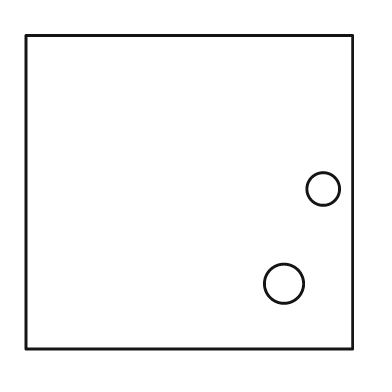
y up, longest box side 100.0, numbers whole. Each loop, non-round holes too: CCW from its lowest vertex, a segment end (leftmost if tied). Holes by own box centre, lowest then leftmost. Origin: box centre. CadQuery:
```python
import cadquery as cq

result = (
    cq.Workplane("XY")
    .moveTo(-50.0, -48.0)
    .lineTo(50.0, -48.0)
    .lineTo(50.0, 48.0)
    .lineTo(-50.0, 48.0)
    .close()
    .moveTo(29.0, -28.0)
    .circle(6.0)
    .moveTo(41.0, 1.0)
    .circle(5.0)
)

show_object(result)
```